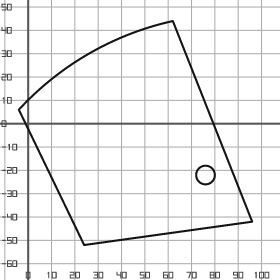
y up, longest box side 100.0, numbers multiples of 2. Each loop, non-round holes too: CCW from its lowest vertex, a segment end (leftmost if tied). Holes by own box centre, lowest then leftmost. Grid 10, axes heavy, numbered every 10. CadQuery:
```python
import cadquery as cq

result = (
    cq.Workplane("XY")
    .moveTo(24.0, -52.0)
    .lineTo(96.0, -42.0)
    .lineTo(62.0, 44.0)
    .threePointArc((26.0, 30.0), (-4.0, 6.0))
    .close()
    .moveTo(76.0, -22.0)
    .circle(4.0)
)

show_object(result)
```